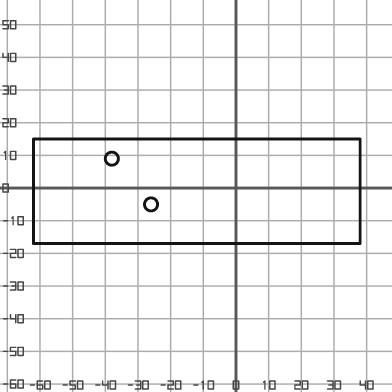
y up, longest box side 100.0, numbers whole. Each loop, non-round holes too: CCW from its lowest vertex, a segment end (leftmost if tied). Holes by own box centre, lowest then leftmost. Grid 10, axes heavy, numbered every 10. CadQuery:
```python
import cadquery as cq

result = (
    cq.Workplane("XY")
    .moveTo(-62.0, -17.0)
    .lineTo(38.0, -17.0)
    .lineTo(38.0, 15.0)
    .lineTo(-62.0, 15.0)
    .close()
    .moveTo(-26.0, -5.0)
    .circle(2.0)
    .moveTo(-38.0, 9.0)
    .circle(2.0)
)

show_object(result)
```